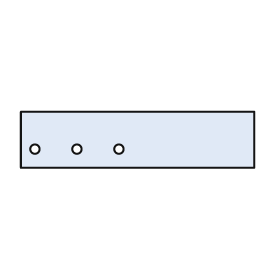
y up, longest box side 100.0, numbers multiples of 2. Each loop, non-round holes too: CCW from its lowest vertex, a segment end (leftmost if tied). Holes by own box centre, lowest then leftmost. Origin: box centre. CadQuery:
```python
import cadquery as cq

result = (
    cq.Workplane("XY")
    .moveTo(-50.0, -12.0)
    .lineTo(50.0, -12.0)
    .lineTo(50.0, 12.0)
    .lineTo(-50.0, 12.0)
    .close()
    .moveTo(-44.0, -4.0)
    .circle(2.0)
    .moveTo(-26.0, -4.0)
    .circle(2.0)
    .moveTo(-8.0, -4.0)
    .circle(2.0)
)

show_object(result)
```